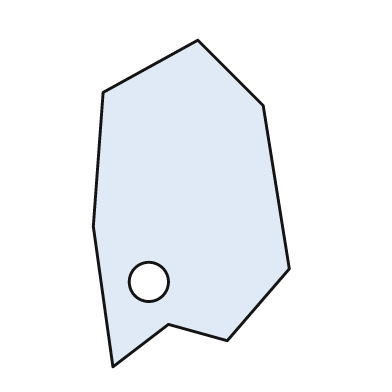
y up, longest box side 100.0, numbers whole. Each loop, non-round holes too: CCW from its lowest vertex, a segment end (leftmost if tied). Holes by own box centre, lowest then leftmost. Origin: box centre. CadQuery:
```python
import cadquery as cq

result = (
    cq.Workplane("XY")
    .moveTo(-24.0, -50.0)
    .lineTo(-7.0, -37.0)
    .lineTo(11.0, -42.0)
    .lineTo(30.0, -20.0)
    .lineTo(22.0, 30.0)
    .lineTo(2.0, 50.0)
    .lineTo(-27.0, 34.0)
    .lineTo(-30.0, -7.0)
    .close()
    .moveTo(-13.0, -24.0)
    .circle(6.0)
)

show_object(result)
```